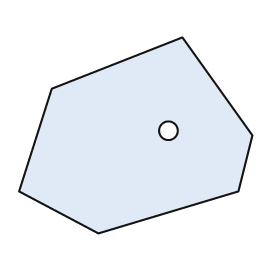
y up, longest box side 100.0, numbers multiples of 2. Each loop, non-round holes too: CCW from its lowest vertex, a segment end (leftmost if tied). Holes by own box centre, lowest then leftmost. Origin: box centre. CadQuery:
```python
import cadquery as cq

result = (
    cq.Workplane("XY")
    .moveTo(-16.0, -42.0)
    .lineTo(44.0, -24.0)
    .lineTo(50.0, 0.0)
    .lineTo(20.0, 42.0)
    .lineTo(-36.0, 20.0)
    .lineTo(-50.0, -24.0)
    .close()
    .moveTo(14.0, 2.0)
    .circle(4.0)
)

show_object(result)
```